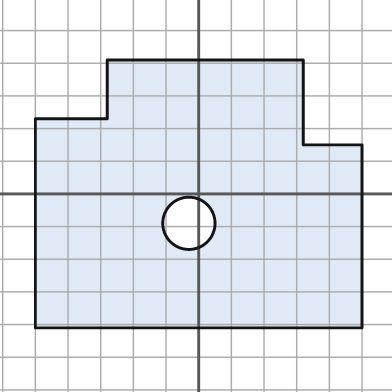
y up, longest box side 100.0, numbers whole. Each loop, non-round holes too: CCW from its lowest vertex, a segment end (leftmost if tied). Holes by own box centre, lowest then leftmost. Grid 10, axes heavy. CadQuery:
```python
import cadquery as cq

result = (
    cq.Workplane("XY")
    .moveTo(-50.0, -41.0)
    .lineTo(50.0, -41.0)
    .lineTo(50.0, 15.0)
    .lineTo(32.0, 15.0)
    .lineTo(32.0, 41.0)
    .lineTo(-28.0, 41.0)
    .lineTo(-28.0, 23.0)
    .lineTo(-50.0, 23.0)
    .close()
    .moveTo(-3.0, -9.0)
    .circle(8.0)
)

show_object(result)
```